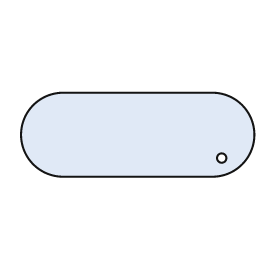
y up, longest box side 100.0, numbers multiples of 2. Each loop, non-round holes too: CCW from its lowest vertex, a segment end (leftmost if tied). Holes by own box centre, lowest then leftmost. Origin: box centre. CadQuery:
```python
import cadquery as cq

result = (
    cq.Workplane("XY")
    .moveTo(-32.0, -18.0)
    .lineTo(32.0, -18.0)
    .threePointArc((50.0, 0.0), (32.0, 18.0))
    .lineTo(-32.0, 18.0)
    .threePointArc((-50.0, 0.0), (-32.0, -18.0))
    .close()
    .moveTo(36.0, -10.0)
    .circle(2.0)
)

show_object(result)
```